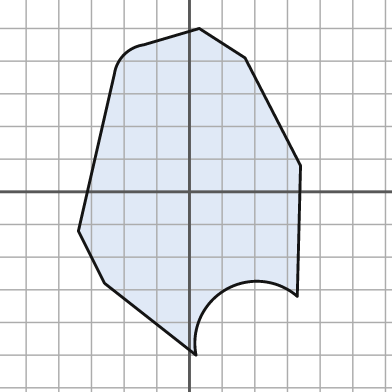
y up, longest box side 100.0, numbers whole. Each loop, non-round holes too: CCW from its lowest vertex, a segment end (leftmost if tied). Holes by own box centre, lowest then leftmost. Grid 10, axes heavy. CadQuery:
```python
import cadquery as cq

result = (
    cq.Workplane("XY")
    .moveTo(2.0, -50.0)
    .threePointArc((11.0, -30.0), (33.0, -32.0))
    .lineTo(34.0, 8.0)
    .lineTo(17.0, 41.0)
    .lineTo(3.0, 50.0)
    .lineTo(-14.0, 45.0)
    .threePointArc((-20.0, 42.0), (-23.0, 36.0))
    .lineTo(-34.0, -12.0)
    .lineTo(-26.0, -28.0)
    .close()
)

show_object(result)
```